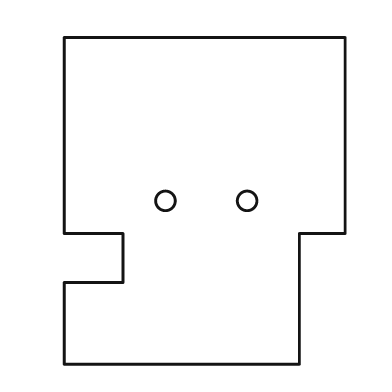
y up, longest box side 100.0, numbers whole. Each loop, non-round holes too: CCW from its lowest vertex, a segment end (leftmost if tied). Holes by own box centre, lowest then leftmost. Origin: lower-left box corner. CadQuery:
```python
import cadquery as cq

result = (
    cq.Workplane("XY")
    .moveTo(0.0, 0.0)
    .lineTo(72.0, 0.0)
    .lineTo(72.0, 40.0)
    .lineTo(86.0, 40.0)
    .lineTo(86.0, 100.0)
    .lineTo(0.0, 100.0)
    .lineTo(0.0, 40.0)
    .lineTo(18.0, 40.0)
    .lineTo(18.0, 25.0)
    .lineTo(0.0, 25.0)
    .close()
    .moveTo(31.0, 50.0)
    .circle(3.0)
    .moveTo(56.0, 50.0)
    .circle(3.0)
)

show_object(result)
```